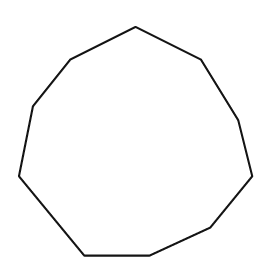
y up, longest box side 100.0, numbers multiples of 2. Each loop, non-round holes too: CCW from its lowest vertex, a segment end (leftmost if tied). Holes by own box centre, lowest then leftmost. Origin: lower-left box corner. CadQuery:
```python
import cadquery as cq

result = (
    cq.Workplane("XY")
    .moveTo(28.0, 0.0)
    .lineTo(56.0, 0.0)
    .lineTo(82.0, 12.0)
    .lineTo(100.0, 34.0)
    .lineTo(94.0, 58.0)
    .lineTo(78.0, 84.0)
    .lineTo(50.0, 98.0)
    .lineTo(22.0, 84.0)
    .lineTo(6.0, 64.0)
    .lineTo(0.0, 34.0)
    .close()
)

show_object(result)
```